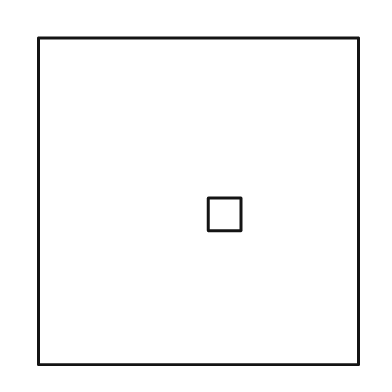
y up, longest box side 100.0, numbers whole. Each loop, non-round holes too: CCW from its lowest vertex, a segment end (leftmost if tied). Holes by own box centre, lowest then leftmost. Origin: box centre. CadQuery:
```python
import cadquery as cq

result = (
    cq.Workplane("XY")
    .moveTo(-49.0, -50.0)
    .lineTo(49.0, -50.0)
    .lineTo(49.0, 50.0)
    .lineTo(-49.0, 50.0)
    .close()
    .moveTo(3.0, -9.0)
    .lineTo(13.0, -9.0)
    .lineTo(13.0, 1.0)
    .lineTo(3.0, 1.0)
    .close()
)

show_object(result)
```